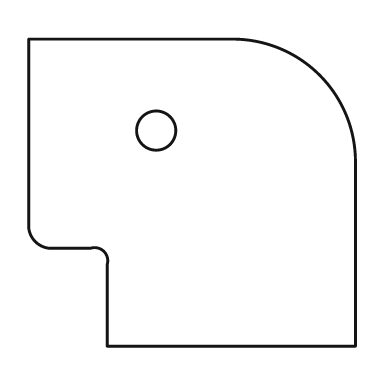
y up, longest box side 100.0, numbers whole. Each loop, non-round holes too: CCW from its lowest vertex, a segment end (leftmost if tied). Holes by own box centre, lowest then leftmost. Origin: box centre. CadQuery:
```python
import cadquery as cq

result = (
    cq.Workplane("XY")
    .moveTo(-26.0, -47.0)
    .lineTo(50.0, -47.0)
    .lineTo(50.0, 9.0)
    .threePointArc((39.0, 36.0), (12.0, 47.0))
    .lineTo(-50.0, 47.0)
    .lineTo(-50.0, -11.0)
    .threePointArc((-48.0, -15.0), (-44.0, -17.0))
    .lineTo(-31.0, -17.0)
    .threePointArc((-27.0, -18.0), (-26.0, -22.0))
    .close()
    .moveTo(-11.0, 19.0)
    .circle(6.0)
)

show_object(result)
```